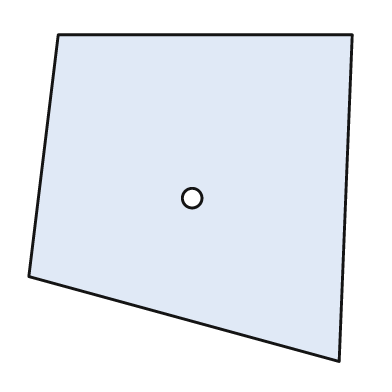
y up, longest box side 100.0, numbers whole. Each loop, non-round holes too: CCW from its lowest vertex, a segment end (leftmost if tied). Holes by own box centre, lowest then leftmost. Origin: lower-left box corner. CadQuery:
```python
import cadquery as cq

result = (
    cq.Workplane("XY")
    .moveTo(95.0, 0.0)
    .lineTo(99.0, 100.0)
    .lineTo(9.0, 100.0)
    .lineTo(0.0, 26.0)
    .close()
    .moveTo(50.0, 50.0)
    .circle(3.0)
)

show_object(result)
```